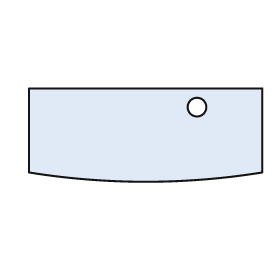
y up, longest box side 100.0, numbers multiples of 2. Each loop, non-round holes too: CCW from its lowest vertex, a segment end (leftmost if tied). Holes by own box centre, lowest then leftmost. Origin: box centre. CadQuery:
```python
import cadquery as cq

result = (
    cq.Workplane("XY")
    .moveTo(-50.0, -16.0)
    .threePointArc((0.0, -20.0), (50.0, -16.0))
    .lineTo(50.0, 20.0)
    .lineTo(-50.0, 20.0)
    .close()
    .moveTo(22.0, 12.0)
    .circle(4.0)
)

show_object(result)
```